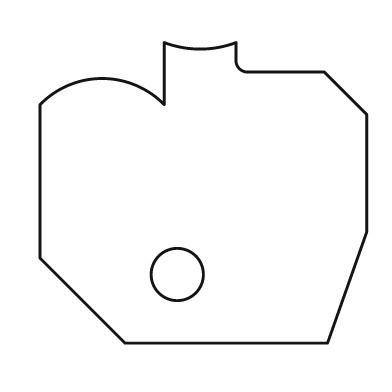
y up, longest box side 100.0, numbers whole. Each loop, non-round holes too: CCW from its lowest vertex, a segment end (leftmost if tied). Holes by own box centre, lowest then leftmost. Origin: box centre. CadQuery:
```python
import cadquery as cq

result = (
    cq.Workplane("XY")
    .moveTo(-24.0, -46.0)
    .lineTo(38.0, -46.0)
    .lineTo(50.0, -12.0)
    .lineTo(50.0, 24.0)
    .lineTo(37.0, 37.0)
    .lineTo(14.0, 37.0)
    .threePointArc((11.0, 38.0), (10.0, 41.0))
    .lineTo(10.0, 46.0)
    .threePointArc((-1.0, 44.0), (-12.0, 46.0))
    .lineTo(-12.0, 27.0)
    .threePointArc((-31.0, 35.0), (-50.0, 27.0))
    .lineTo(-50.0, -20.0)
    .close()
    .moveTo(-8.0, -25.0)
    .circle(8.0)
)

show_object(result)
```